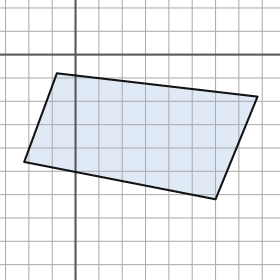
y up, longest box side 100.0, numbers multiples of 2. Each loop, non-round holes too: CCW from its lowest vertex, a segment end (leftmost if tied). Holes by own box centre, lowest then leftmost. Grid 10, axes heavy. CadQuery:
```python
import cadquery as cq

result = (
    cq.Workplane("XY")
    .moveTo(60.0, -62.0)
    .lineTo(78.0, -18.0)
    .lineTo(-8.0, -8.0)
    .lineTo(-22.0, -46.0)
    .close()
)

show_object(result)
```